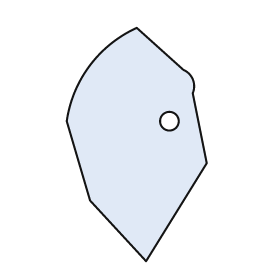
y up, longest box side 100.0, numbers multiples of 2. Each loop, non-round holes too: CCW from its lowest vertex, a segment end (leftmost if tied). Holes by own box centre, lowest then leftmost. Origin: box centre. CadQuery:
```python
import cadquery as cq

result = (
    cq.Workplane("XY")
    .moveTo(4.0, -50.0)
    .lineTo(30.0, -8.0)
    .lineTo(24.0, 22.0)
    .threePointArc((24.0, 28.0), (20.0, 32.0))
    .lineTo(0.0, 50.0)
    .threePointArc((-20.0, 34.0), (-30.0, 10.0))
    .lineTo(-20.0, -24.0)
    .close()
    .moveTo(14.0, 10.0)
    .circle(4.0)
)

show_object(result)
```